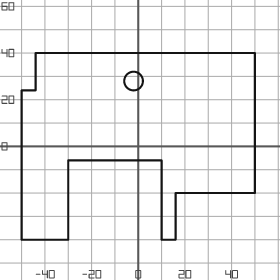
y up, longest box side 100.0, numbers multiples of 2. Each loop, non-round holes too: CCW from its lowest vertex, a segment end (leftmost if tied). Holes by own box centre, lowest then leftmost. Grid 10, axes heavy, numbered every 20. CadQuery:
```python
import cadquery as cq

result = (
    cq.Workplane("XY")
    .moveTo(-50.0, -40.0)
    .lineTo(-30.0, -40.0)
    .lineTo(-30.0, -6.0)
    .lineTo(10.0, -6.0)
    .lineTo(10.0, -40.0)
    .lineTo(16.0, -40.0)
    .lineTo(16.0, -20.0)
    .lineTo(50.0, -20.0)
    .lineTo(50.0, 40.0)
    .lineTo(-44.0, 40.0)
    .lineTo(-44.0, 24.0)
    .lineTo(-50.0, 24.0)
    .close()
    .moveTo(-2.0, 28.0)
    .circle(4.0)
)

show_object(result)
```